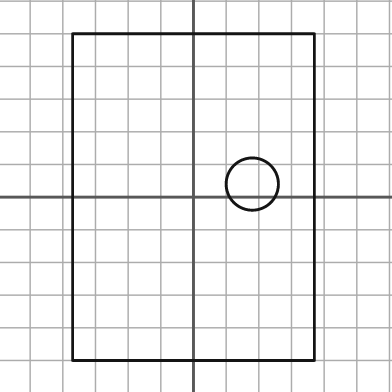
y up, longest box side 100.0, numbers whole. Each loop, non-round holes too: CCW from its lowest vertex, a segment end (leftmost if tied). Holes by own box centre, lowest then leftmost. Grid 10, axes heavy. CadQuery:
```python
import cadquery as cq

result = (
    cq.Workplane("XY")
    .moveTo(-37.0, -50.0)
    .lineTo(37.0, -50.0)
    .lineTo(37.0, 50.0)
    .lineTo(-37.0, 50.0)
    .close()
    .moveTo(18.0, 4.0)
    .circle(8.0)
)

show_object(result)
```